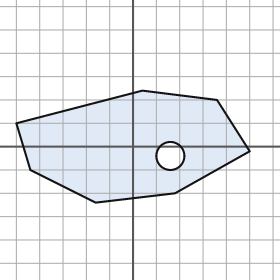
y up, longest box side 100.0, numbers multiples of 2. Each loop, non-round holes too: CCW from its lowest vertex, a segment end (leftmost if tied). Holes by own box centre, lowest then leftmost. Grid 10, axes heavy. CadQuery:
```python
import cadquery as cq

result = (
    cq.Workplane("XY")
    .moveTo(-16.0, -24.0)
    .lineTo(18.0, -20.0)
    .lineTo(50.0, -2.0)
    .lineTo(36.0, 20.0)
    .lineTo(4.0, 24.0)
    .lineTo(-50.0, 10.0)
    .lineTo(-44.0, -10.0)
    .close()
    .moveTo(16.0, -4.0)
    .circle(6.0)
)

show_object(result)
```